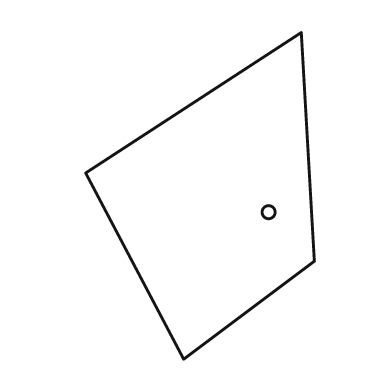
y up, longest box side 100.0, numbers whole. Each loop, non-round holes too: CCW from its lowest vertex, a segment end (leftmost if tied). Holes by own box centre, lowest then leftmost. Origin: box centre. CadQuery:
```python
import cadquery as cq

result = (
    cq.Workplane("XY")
    .moveTo(-5.0, -50.0)
    .lineTo(35.0, -20.0)
    .lineTo(31.0, 50.0)
    .lineTo(-35.0, 7.0)
    .close()
    .moveTo(21.0, -5.0)
    .circle(2.0)
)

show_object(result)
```